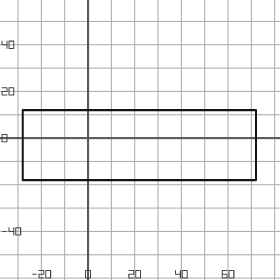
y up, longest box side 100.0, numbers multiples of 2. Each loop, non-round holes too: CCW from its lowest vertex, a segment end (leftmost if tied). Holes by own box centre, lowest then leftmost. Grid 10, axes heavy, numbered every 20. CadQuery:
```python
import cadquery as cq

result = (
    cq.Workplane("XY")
    .moveTo(-28.0, -18.0)
    .lineTo(72.0, -18.0)
    .lineTo(72.0, 12.0)
    .lineTo(-28.0, 12.0)
    .close()
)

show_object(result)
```